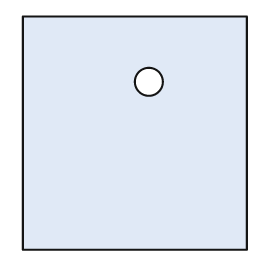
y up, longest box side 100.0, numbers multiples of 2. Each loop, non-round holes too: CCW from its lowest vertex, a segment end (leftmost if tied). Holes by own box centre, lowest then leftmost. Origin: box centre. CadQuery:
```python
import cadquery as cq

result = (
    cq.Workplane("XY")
    .moveTo(-48.0, -50.0)
    .lineTo(48.0, -50.0)
    .lineTo(48.0, 50.0)
    .lineTo(-48.0, 50.0)
    .close()
    .moveTo(6.0, 22.0)
    .circle(6.0)
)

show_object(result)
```